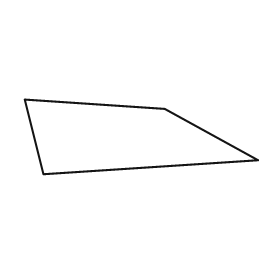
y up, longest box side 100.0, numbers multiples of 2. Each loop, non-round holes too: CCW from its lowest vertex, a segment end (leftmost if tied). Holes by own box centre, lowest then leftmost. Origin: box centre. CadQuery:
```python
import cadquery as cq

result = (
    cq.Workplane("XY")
    .moveTo(-42.0, -16.0)
    .lineTo(50.0, -10.0)
    .lineTo(10.0, 12.0)
    .lineTo(-50.0, 16.0)
    .close()
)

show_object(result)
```